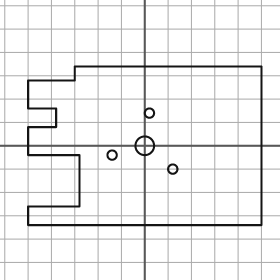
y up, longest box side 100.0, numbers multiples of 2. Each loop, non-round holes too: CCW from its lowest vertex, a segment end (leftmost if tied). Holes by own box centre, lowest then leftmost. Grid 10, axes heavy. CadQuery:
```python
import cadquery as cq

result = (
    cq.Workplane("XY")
    .moveTo(-50.0, -34.0)
    .lineTo(50.0, -34.0)
    .lineTo(50.0, 34.0)
    .lineTo(-30.0, 34.0)
    .lineTo(-30.0, 28.0)
    .lineTo(-50.0, 28.0)
    .lineTo(-50.0, 16.0)
    .lineTo(-38.0, 16.0)
    .lineTo(-38.0, 8.0)
    .lineTo(-50.0, 8.0)
    .lineTo(-50.0, -4.0)
    .lineTo(-28.0, -4.0)
    .lineTo(-28.0, -26.0)
    .lineTo(-50.0, -26.0)
    .close()
    .moveTo(12.0, -10.0)
    .circle(2.0)
    .moveTo(-14.0, -4.0)
    .circle(2.0)
    .moveTo(0.0, 0.0)
    .circle(4.0)
    .moveTo(2.0, 14.0)
    .circle(2.0)
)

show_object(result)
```